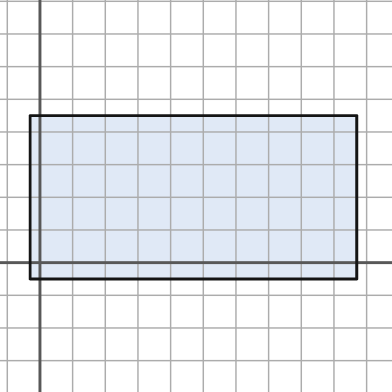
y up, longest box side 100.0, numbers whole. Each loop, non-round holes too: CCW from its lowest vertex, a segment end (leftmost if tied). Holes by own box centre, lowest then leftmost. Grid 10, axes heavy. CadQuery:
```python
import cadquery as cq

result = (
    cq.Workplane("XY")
    .moveTo(-3.0, -5.0)
    .lineTo(97.0, -5.0)
    .lineTo(97.0, 45.0)
    .lineTo(-3.0, 45.0)
    .close()
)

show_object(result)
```